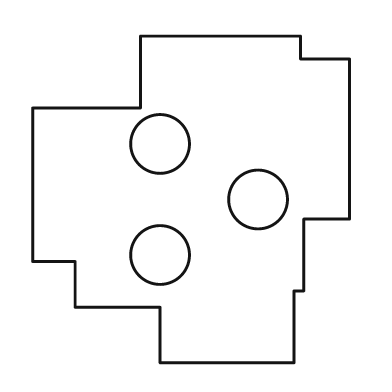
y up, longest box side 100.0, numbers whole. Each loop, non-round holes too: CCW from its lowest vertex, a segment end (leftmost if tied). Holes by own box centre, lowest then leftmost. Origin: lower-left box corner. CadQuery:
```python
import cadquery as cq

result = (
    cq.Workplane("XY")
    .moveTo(39.0, 0.0)
    .lineTo(80.0, 0.0)
    .lineTo(80.0, 22.0)
    .lineTo(83.0, 22.0)
    .lineTo(83.0, 44.0)
    .lineTo(97.0, 44.0)
    .lineTo(97.0, 93.0)
    .lineTo(82.0, 93.0)
    .lineTo(82.0, 100.0)
    .lineTo(33.0, 100.0)
    .lineTo(33.0, 78.0)
    .lineTo(0.0, 78.0)
    .lineTo(0.0, 31.0)
    .lineTo(13.0, 31.0)
    .lineTo(13.0, 17.0)
    .lineTo(39.0, 17.0)
    .close()
    .moveTo(39.0, 33.0)
    .circle(9.0)
    .moveTo(69.0, 50.0)
    .circle(9.0)
    .moveTo(39.0, 67.0)
    .circle(9.0)
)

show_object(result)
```